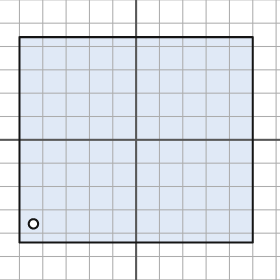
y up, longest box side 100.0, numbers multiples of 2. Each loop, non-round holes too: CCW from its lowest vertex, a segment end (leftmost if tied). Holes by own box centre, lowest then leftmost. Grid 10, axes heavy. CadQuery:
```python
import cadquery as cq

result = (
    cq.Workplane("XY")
    .moveTo(-50.0, -44.0)
    .lineTo(50.0, -44.0)
    .lineTo(50.0, 44.0)
    .lineTo(-50.0, 44.0)
    .close()
    .moveTo(-44.0, -36.0)
    .circle(2.0)
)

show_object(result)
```